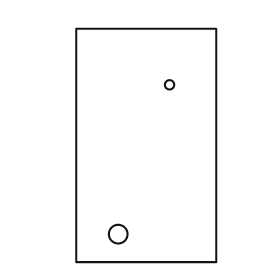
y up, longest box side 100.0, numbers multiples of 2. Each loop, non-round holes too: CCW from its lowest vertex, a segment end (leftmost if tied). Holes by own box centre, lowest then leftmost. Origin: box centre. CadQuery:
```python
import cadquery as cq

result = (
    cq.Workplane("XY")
    .moveTo(-30.0, -50.0)
    .lineTo(30.0, -50.0)
    .lineTo(30.0, 50.0)
    .lineTo(-30.0, 50.0)
    .close()
    .moveTo(-12.0, -38.0)
    .circle(4.0)
    .moveTo(10.0, 26.0)
    .circle(2.0)
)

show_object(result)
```